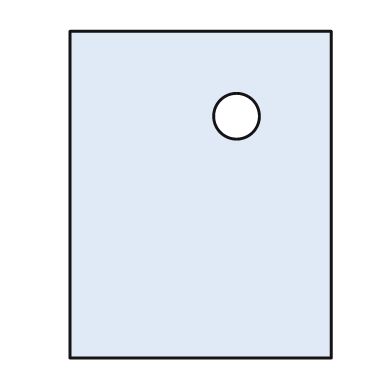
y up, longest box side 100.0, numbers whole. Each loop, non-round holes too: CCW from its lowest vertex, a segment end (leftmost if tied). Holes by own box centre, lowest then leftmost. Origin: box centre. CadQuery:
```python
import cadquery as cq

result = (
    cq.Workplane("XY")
    .moveTo(-40.0, -50.0)
    .lineTo(40.0, -50.0)
    .lineTo(40.0, 50.0)
    .lineTo(-40.0, 50.0)
    .close()
    .moveTo(11.0, 24.0)
    .circle(7.0)
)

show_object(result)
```